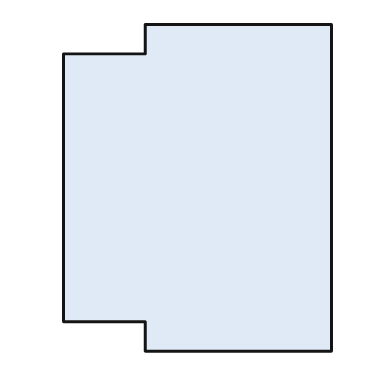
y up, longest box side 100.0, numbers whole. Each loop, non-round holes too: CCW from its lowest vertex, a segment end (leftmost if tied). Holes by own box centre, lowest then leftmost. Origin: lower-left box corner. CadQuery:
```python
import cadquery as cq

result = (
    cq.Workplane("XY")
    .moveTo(25.0, 0.0)
    .lineTo(82.0, 0.0)
    .lineTo(82.0, 100.0)
    .lineTo(25.0, 100.0)
    .lineTo(25.0, 91.0)
    .lineTo(0.0, 91.0)
    .lineTo(0.0, 9.0)
    .lineTo(25.0, 9.0)
    .close()
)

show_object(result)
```